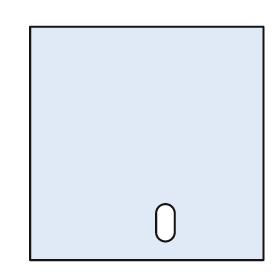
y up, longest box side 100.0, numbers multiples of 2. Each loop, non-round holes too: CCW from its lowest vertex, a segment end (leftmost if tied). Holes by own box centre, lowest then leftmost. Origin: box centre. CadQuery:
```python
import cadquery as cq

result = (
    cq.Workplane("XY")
    .moveTo(-50.0, -50.0)
    .lineTo(50.0, -50.0)
    .lineTo(50.0, 50.0)
    .lineTo(-50.0, 50.0)
    .close()
    .moveTo(4.0, -38.0)
    .threePointArc((8.0, -42.0), (12.0, -38.0))
    .lineTo(12.0, -30.0)
    .threePointArc((8.0, -26.0), (4.0, -30.0))
    .close()
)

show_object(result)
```